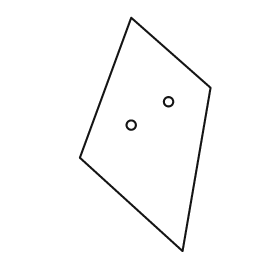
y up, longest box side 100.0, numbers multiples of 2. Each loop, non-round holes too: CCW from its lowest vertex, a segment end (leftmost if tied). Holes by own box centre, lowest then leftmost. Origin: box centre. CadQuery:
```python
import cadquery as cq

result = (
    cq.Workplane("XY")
    .moveTo(16.0, -50.0)
    .lineTo(28.0, 20.0)
    .lineTo(-6.0, 50.0)
    .lineTo(-28.0, -10.0)
    .close()
    .moveTo(-6.0, 4.0)
    .circle(2.0)
    .moveTo(10.0, 14.0)
    .circle(2.0)
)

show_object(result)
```